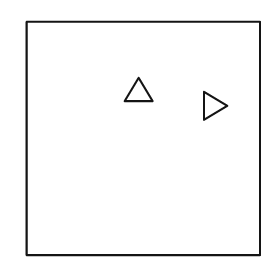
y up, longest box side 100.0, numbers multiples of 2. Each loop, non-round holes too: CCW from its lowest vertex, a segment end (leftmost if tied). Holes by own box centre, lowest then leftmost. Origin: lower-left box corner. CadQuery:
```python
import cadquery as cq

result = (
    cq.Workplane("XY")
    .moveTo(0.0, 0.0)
    .lineTo(100.0, 0.0)
    .lineTo(100.0, 100.0)
    .lineTo(0.0, 100.0)
    .close()
    .moveTo(76.0, 58.0)
    .lineTo(86.0, 64.0)
    .lineTo(76.0, 70.0)
    .close()
    .moveTo(42.0, 66.0)
    .lineTo(54.0, 66.0)
    .lineTo(48.0, 76.0)
    .close()
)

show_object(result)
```